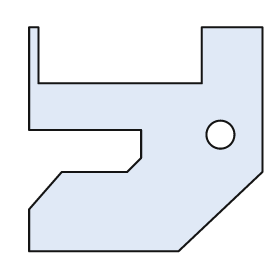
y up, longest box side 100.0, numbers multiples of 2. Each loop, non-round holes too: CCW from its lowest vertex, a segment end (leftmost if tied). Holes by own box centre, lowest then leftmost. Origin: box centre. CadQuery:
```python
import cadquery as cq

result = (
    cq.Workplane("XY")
    .moveTo(-50.0, -48.0)
    .lineTo(14.0, -48.0)
    .lineTo(50.0, -14.0)
    .lineTo(50.0, 48.0)
    .lineTo(24.0, 48.0)
    .lineTo(24.0, 24.0)
    .lineTo(-46.0, 24.0)
    .lineTo(-46.0, 48.0)
    .lineTo(-50.0, 48.0)
    .lineTo(-50.0, 4.0)
    .lineTo(-2.0, 4.0)
    .lineTo(-2.0, -8.0)
    .lineTo(-8.0, -14.0)
    .lineTo(-36.0, -14.0)
    .lineTo(-50.0, -30.0)
    .close()
    .moveTo(32.0, 2.0)
    .circle(6.0)
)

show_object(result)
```